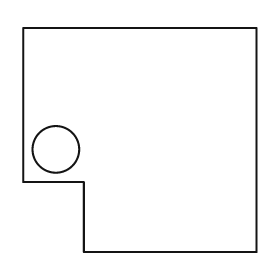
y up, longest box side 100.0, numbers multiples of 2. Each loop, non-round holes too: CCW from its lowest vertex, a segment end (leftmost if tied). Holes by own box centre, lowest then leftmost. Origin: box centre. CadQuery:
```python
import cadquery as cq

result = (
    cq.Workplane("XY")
    .moveTo(-24.0, -48.0)
    .lineTo(50.0, -48.0)
    .lineTo(50.0, 48.0)
    .lineTo(-50.0, 48.0)
    .lineTo(-50.0, -18.0)
    .lineTo(-24.0, -18.0)
    .close()
    .moveTo(-36.0, -4.0)
    .circle(10.0)
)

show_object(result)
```